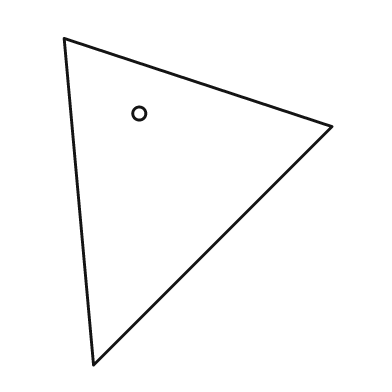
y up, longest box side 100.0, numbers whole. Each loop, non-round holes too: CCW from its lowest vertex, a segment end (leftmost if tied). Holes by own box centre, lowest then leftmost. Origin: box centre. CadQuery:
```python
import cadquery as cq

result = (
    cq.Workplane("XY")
    .moveTo(-32.0, -50.0)
    .lineTo(41.0, 23.0)
    .lineTo(-41.0, 50.0)
    .close()
    .moveTo(-18.0, 27.0)
    .circle(2.0)
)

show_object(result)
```